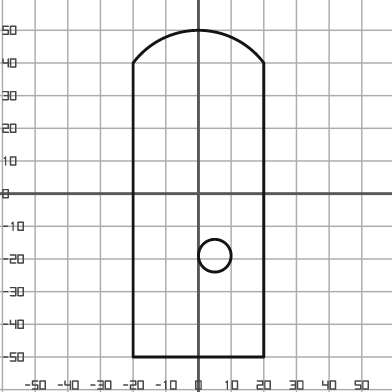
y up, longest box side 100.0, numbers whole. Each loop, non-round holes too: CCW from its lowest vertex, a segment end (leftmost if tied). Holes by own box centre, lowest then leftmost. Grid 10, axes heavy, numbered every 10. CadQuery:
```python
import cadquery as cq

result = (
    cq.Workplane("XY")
    .moveTo(-20.0, -50.0)
    .lineTo(20.0, -50.0)
    .lineTo(20.0, 40.0)
    .threePointArc((0.0, 50.0), (-20.0, 40.0))
    .close()
    .moveTo(5.0, -19.0)
    .circle(5.0)
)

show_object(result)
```